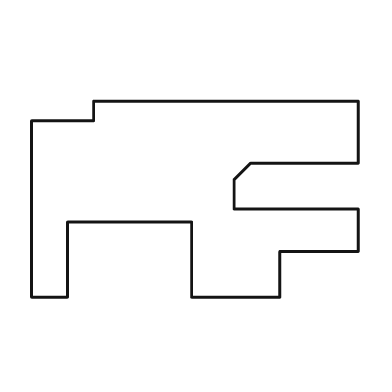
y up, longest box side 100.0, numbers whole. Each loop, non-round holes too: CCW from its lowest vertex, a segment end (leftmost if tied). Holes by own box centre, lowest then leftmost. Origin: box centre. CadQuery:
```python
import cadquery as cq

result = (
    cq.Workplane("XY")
    .moveTo(-50.0, -30.0)
    .lineTo(-39.0, -30.0)
    .lineTo(-39.0, -7.0)
    .lineTo(-1.0, -7.0)
    .lineTo(-1.0, -30.0)
    .lineTo(26.0, -30.0)
    .lineTo(26.0, -16.0)
    .lineTo(50.0, -16.0)
    .lineTo(50.0, -3.0)
    .lineTo(12.0, -3.0)
    .lineTo(12.0, 6.0)
    .lineTo(17.0, 11.0)
    .lineTo(50.0, 11.0)
    .lineTo(50.0, 30.0)
    .lineTo(-31.0, 30.0)
    .lineTo(-31.0, 24.0)
    .lineTo(-50.0, 24.0)
    .close()
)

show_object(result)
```